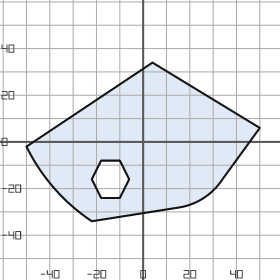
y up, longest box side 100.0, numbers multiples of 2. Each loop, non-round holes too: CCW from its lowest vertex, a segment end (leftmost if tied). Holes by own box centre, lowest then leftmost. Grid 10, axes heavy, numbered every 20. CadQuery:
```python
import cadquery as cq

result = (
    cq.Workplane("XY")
    .moveTo(-22.0, -34.0)
    .lineTo(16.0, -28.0)
    .threePointArc((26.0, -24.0), (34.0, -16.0))
    .lineTo(50.0, 6.0)
    .lineTo(4.0, 34.0)
    .lineTo(-50.0, -2.0)
    .threePointArc((-38.0, -20.0), (-22.0, -34.0))
    .close()
    .moveTo(-18.0, -24.0)
    .lineTo(-10.0, -24.0)
    .lineTo(-6.0, -16.0)
    .lineTo(-10.0, -8.0)
    .lineTo(-18.0, -8.0)
    .lineTo(-22.0, -16.0)
    .close()
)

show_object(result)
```